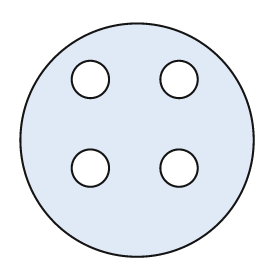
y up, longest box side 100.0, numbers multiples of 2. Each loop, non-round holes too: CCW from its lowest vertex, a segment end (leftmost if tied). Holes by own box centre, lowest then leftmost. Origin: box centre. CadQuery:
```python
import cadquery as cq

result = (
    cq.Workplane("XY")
    .moveTo(0.0, 0.0)
    .circle(50.0)
    .moveTo(-20.0, -12.0)
    .circle(8.0)
    .moveTo(18.0, -12.0)
    .circle(8.0)
    .moveTo(-20.0, 26.0)
    .circle(8.0)
    .moveTo(18.0, 26.0)
    .circle(8.0)
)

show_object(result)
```